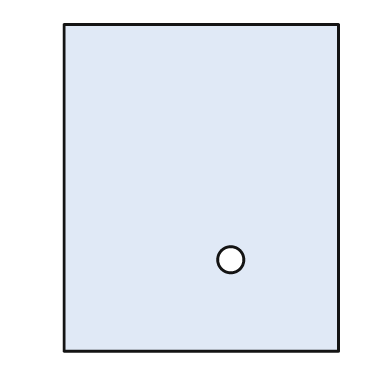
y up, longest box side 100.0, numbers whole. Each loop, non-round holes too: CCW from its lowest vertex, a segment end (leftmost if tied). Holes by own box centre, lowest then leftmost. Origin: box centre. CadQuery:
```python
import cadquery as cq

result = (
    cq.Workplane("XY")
    .moveTo(-42.0, -50.0)
    .lineTo(42.0, -50.0)
    .lineTo(42.0, 50.0)
    .lineTo(-42.0, 50.0)
    .close()
    .moveTo(9.0, -22.0)
    .circle(4.0)
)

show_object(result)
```